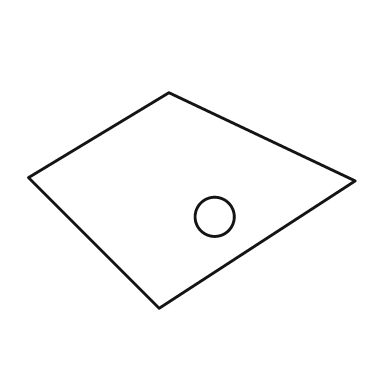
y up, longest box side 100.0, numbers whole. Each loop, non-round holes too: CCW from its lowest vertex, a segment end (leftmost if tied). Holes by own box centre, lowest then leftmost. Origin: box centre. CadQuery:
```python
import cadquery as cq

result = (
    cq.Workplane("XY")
    .moveTo(-10.0, -33.0)
    .lineTo(50.0, 6.0)
    .lineTo(-7.0, 33.0)
    .lineTo(-50.0, 7.0)
    .close()
    .moveTo(7.0, -5.0)
    .circle(6.0)
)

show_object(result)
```